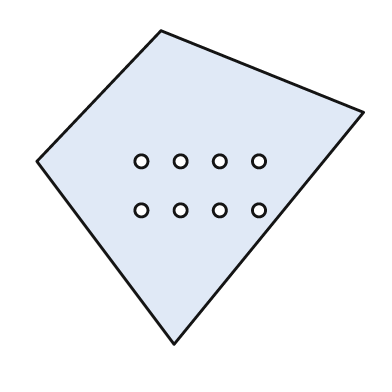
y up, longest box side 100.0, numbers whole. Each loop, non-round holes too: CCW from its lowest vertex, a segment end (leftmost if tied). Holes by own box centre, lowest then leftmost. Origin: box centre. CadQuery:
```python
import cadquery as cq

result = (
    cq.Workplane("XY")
    .moveTo(-8.0, -48.0)
    .lineTo(50.0, 23.0)
    .lineTo(-12.0, 48.0)
    .lineTo(-50.0, 8.0)
    .close()
    .moveTo(-18.0, -7.0)
    .circle(2.0)
    .moveTo(-6.0, -7.0)
    .circle(2.0)
    .moveTo(6.0, -7.0)
    .circle(2.0)
    .moveTo(18.0, -7.0)
    .circle(2.0)
    .moveTo(-18.0, 8.0)
    .circle(2.0)
    .moveTo(-6.0, 8.0)
    .circle(2.0)
    .moveTo(6.0, 8.0)
    .circle(2.0)
    .moveTo(18.0, 8.0)
    .circle(2.0)
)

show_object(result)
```